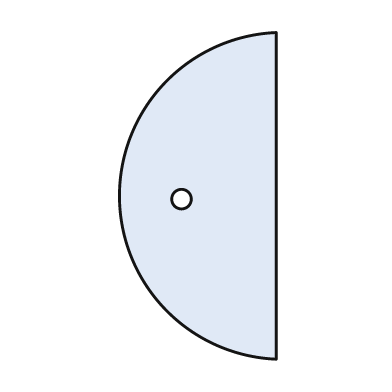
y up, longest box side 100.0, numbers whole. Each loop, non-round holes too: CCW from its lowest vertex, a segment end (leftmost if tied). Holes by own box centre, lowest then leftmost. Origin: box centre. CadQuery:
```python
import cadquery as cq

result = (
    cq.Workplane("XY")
    .moveTo(24.0, -50.0)
    .lineTo(24.0, 50.0)
    .threePointArc((-24.0, 0.0), (24.0, -50.0))
    .close()
    .moveTo(-5.0, -1.0)
    .circle(3.0)
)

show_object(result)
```